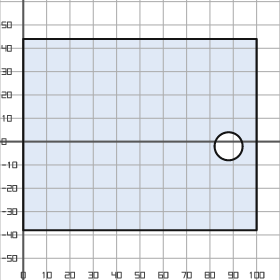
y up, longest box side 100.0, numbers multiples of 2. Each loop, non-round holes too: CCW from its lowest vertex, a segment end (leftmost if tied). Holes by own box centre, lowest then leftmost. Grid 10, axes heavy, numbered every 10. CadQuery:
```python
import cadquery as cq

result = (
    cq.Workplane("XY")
    .moveTo(0.0, -38.0)
    .lineTo(100.0, -38.0)
    .lineTo(100.0, 44.0)
    .lineTo(0.0, 44.0)
    .close()
    .moveTo(88.0, -2.0)
    .circle(6.0)
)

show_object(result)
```